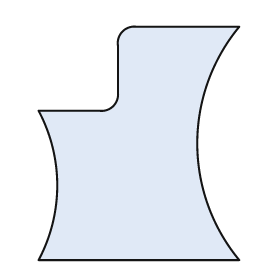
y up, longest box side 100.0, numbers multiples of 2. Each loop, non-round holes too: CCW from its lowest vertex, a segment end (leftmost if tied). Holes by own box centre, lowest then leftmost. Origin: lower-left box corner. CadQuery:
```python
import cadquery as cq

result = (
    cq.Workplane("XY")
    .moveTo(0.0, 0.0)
    .lineTo(86.0, 0.0)
    .threePointArc((68.0, 50.0), (86.0, 100.0))
    .lineTo(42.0, 100.0)
    .threePointArc((36.0, 98.0), (34.0, 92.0))
    .lineTo(34.0, 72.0)
    .threePointArc((32.0, 66.0), (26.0, 64.0))
    .lineTo(0.0, 64.0)
    .threePointArc((8.0, 32.0), (0.0, 0.0))
    .close()
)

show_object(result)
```